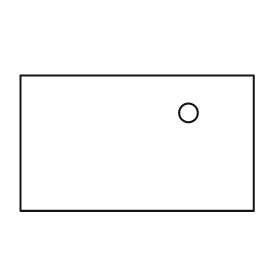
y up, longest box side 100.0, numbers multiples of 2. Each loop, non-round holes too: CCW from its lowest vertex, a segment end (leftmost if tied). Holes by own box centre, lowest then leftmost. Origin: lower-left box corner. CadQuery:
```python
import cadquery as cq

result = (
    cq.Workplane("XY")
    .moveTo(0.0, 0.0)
    .lineTo(100.0, 0.0)
    .lineTo(100.0, 58.0)
    .lineTo(0.0, 58.0)
    .close()
    .moveTo(72.0, 42.0)
    .circle(4.0)
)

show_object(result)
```